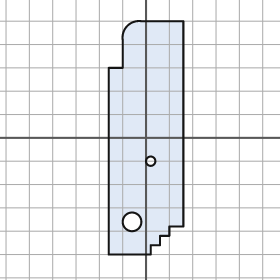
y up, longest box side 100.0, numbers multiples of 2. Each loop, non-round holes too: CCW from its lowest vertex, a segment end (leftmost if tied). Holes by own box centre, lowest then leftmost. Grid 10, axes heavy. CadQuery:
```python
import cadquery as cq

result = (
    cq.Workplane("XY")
    .moveTo(-16.0, -50.0)
    .lineTo(2.0, -50.0)
    .lineTo(2.0, -46.0)
    .lineTo(6.0, -46.0)
    .lineTo(6.0, -42.0)
    .lineTo(10.0, -42.0)
    .lineTo(10.0, -38.0)
    .lineTo(16.0, -38.0)
    .lineTo(16.0, 50.0)
    .lineTo(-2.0, 50.0)
    .threePointArc((-8.0, 48.0), (-10.0, 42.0))
    .lineTo(-10.0, 30.0)
    .lineTo(-16.0, 30.0)
    .close()
    .moveTo(-6.0, -36.0)
    .circle(4.0)
    .moveTo(2.0, -10.0)
    .circle(2.0)
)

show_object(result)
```